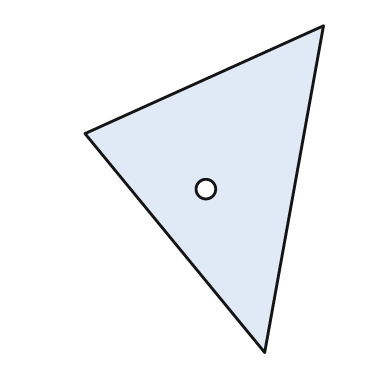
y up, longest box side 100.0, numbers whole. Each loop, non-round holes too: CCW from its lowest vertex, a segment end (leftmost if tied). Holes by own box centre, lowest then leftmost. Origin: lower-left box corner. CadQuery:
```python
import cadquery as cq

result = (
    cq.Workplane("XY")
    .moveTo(55.0, 0.0)
    .lineTo(73.0, 100.0)
    .lineTo(0.0, 67.0)
    .close()
    .moveTo(37.0, 50.0)
    .circle(3.0)
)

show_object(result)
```